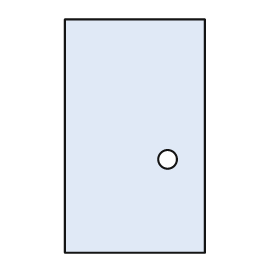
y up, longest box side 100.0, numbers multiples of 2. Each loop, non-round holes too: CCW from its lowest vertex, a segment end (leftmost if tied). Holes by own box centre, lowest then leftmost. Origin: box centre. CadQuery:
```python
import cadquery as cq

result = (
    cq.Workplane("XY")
    .moveTo(-30.0, -50.0)
    .lineTo(30.0, -50.0)
    .lineTo(30.0, 50.0)
    .lineTo(-30.0, 50.0)
    .close()
    .moveTo(14.0, -10.0)
    .circle(4.0)
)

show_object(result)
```